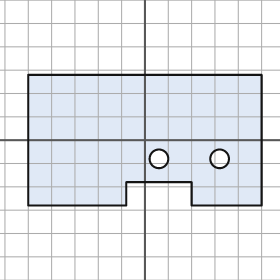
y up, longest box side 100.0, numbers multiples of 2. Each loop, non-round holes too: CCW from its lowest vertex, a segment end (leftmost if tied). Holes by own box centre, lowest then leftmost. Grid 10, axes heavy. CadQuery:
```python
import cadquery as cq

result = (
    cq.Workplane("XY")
    .moveTo(-50.0, -28.0)
    .lineTo(-8.0, -28.0)
    .lineTo(-8.0, -18.0)
    .lineTo(20.0, -18.0)
    .lineTo(20.0, -28.0)
    .lineTo(50.0, -28.0)
    .lineTo(50.0, 28.0)
    .lineTo(-50.0, 28.0)
    .close()
    .moveTo(6.0, -8.0)
    .circle(4.0)
    .moveTo(32.0, -8.0)
    .circle(4.0)
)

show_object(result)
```